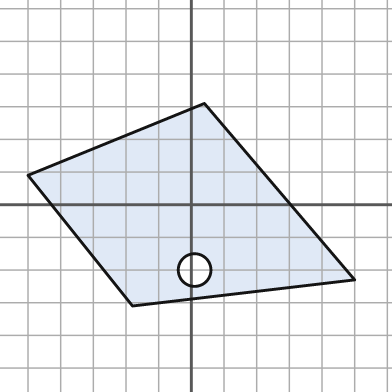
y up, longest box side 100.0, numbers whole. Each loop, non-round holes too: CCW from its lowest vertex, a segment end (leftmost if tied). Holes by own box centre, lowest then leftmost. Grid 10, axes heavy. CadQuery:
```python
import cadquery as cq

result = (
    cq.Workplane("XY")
    .moveTo(-18.0, -31.0)
    .lineTo(50.0, -23.0)
    .lineTo(4.0, 31.0)
    .lineTo(-50.0, 9.0)
    .close()
    .moveTo(1.0, -20.0)
    .circle(5.0)
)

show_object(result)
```